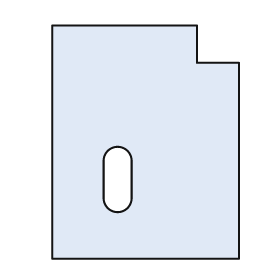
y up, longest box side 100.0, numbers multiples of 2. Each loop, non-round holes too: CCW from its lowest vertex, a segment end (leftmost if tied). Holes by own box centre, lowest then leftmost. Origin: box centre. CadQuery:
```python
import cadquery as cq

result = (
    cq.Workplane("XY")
    .moveTo(-40.0, -50.0)
    .lineTo(40.0, -50.0)
    .lineTo(40.0, 34.0)
    .lineTo(22.0, 34.0)
    .lineTo(22.0, 50.0)
    .lineTo(-40.0, 50.0)
    .close()
    .moveTo(-18.0, -24.0)
    .threePointArc((-12.0, -30.0), (-6.0, -24.0))
    .lineTo(-6.0, -8.0)
    .threePointArc((-12.0, -2.0), (-18.0, -8.0))
    .close()
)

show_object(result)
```